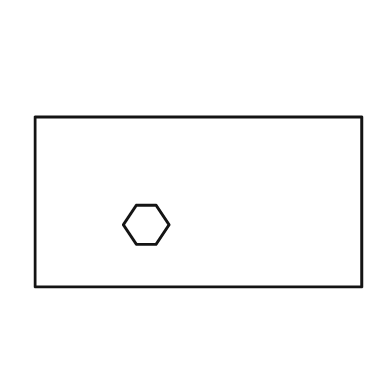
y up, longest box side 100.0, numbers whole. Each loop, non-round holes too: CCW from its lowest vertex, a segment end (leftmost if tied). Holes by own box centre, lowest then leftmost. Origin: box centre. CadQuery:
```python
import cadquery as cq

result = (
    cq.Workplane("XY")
    .moveTo(-50.0, -26.0)
    .lineTo(50.0, -26.0)
    .lineTo(50.0, 26.0)
    .lineTo(-50.0, 26.0)
    .close()
    .moveTo(-19.0, -13.0)
    .lineTo(-13.0, -13.0)
    .lineTo(-9.0, -7.0)
    .lineTo(-13.0, -1.0)
    .lineTo(-19.0, -1.0)
    .lineTo(-23.0, -7.0)
    .close()
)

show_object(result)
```